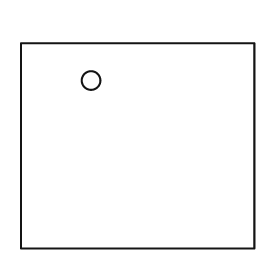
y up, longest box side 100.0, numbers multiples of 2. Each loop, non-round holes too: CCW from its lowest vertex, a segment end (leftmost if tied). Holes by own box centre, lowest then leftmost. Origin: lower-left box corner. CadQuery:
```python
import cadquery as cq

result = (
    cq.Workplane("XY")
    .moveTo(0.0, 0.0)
    .lineTo(100.0, 0.0)
    .lineTo(100.0, 88.0)
    .lineTo(0.0, 88.0)
    .close()
    .moveTo(30.0, 72.0)
    .circle(4.0)
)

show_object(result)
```